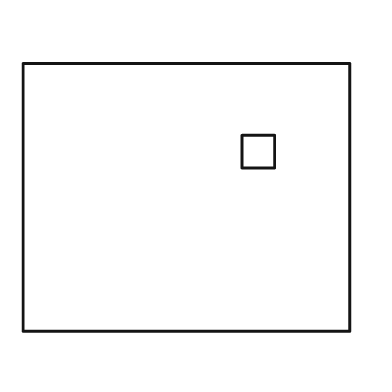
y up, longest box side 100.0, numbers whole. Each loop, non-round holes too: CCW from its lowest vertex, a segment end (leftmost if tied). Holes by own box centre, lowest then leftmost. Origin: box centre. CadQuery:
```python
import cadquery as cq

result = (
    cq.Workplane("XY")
    .moveTo(-50.0, -41.0)
    .lineTo(50.0, -41.0)
    .lineTo(50.0, 41.0)
    .lineTo(-50.0, 41.0)
    .close()
    .moveTo(17.0, 9.0)
    .lineTo(27.0, 9.0)
    .lineTo(27.0, 19.0)
    .lineTo(17.0, 19.0)
    .close()
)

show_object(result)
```